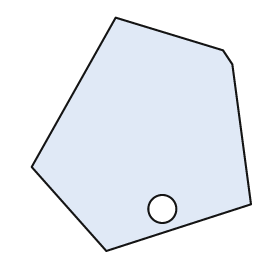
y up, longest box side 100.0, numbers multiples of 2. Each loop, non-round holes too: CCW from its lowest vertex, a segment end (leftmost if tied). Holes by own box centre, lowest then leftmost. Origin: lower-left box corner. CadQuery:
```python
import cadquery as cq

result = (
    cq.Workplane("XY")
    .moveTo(32.0, 0.0)
    .lineTo(94.0, 20.0)
    .lineTo(86.0, 80.0)
    .lineTo(82.0, 86.0)
    .lineTo(36.0, 100.0)
    .lineTo(0.0, 36.0)
    .close()
    .moveTo(56.0, 18.0)
    .circle(6.0)
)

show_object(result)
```